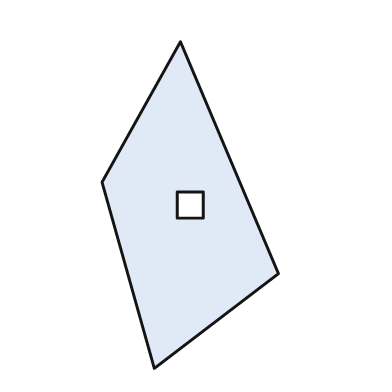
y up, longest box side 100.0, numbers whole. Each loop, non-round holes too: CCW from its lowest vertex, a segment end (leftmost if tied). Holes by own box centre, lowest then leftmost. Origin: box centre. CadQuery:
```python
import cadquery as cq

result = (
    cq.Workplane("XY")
    .moveTo(-11.0, -50.0)
    .lineTo(27.0, -21.0)
    .lineTo(-3.0, 50.0)
    .lineTo(-27.0, 7.0)
    .close()
    .moveTo(-4.0, -4.0)
    .lineTo(4.0, -4.0)
    .lineTo(4.0, 4.0)
    .lineTo(-4.0, 4.0)
    .close()
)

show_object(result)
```